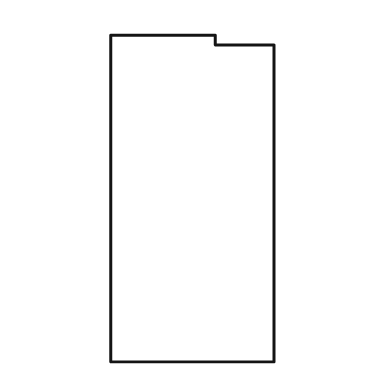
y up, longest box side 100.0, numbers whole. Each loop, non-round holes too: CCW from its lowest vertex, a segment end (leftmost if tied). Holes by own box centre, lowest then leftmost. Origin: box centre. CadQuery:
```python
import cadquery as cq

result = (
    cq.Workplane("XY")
    .moveTo(-25.0, -50.0)
    .lineTo(25.0, -50.0)
    .lineTo(25.0, 47.0)
    .lineTo(7.0, 47.0)
    .lineTo(7.0, 50.0)
    .lineTo(-25.0, 50.0)
    .close()
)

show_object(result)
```